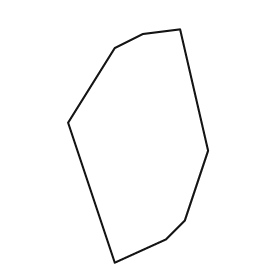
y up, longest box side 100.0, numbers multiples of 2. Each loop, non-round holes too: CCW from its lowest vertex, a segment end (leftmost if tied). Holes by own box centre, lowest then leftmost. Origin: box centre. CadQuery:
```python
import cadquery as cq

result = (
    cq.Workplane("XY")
    .moveTo(-10.0, -50.0)
    .lineTo(12.0, -40.0)
    .lineTo(20.0, -32.0)
    .lineTo(30.0, -2.0)
    .lineTo(18.0, 50.0)
    .lineTo(2.0, 48.0)
    .lineTo(-10.0, 42.0)
    .lineTo(-30.0, 10.0)
    .close()
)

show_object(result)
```